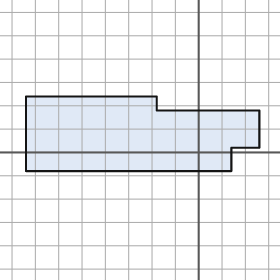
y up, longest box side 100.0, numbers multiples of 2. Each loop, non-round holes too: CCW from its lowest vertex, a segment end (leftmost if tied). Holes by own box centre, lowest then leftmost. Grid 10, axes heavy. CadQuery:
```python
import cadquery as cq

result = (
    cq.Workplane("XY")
    .moveTo(-74.0, -8.0)
    .lineTo(14.0, -8.0)
    .lineTo(14.0, 2.0)
    .lineTo(26.0, 2.0)
    .lineTo(26.0, 18.0)
    .lineTo(-18.0, 18.0)
    .lineTo(-18.0, 24.0)
    .lineTo(-74.0, 24.0)
    .close()
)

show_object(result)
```